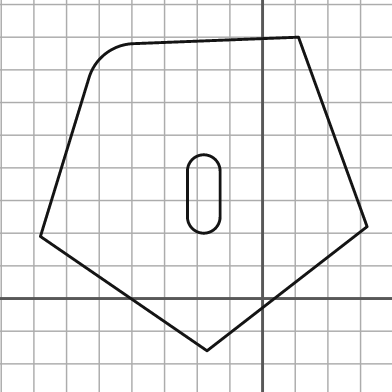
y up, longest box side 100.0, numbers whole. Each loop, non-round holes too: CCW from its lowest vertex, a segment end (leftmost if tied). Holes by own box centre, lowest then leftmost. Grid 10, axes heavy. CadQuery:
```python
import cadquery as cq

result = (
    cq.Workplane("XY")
    .moveTo(-17.0, -16.0)
    .lineTo(32.0, 22.0)
    .lineTo(11.0, 80.0)
    .lineTo(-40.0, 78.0)
    .threePointArc((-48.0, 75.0), (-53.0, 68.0))
    .lineTo(-68.0, 19.0)
    .close()
    .moveTo(-23.0, 25.0)
    .threePointArc((-18.0, 20.0), (-13.0, 25.0))
    .lineTo(-13.0, 39.0)
    .threePointArc((-18.0, 44.0), (-23.0, 39.0))
    .close()
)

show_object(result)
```